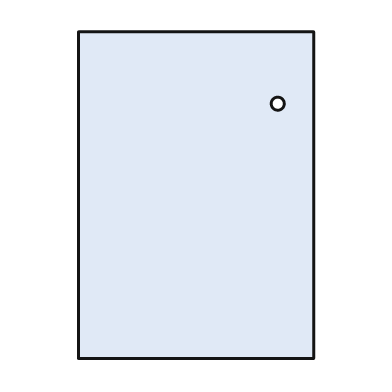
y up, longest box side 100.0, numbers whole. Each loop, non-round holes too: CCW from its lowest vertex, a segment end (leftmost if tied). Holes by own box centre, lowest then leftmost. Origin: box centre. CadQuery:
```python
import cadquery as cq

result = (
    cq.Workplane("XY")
    .moveTo(-36.0, -50.0)
    .lineTo(36.0, -50.0)
    .lineTo(36.0, 50.0)
    .lineTo(-36.0, 50.0)
    .close()
    .moveTo(25.0, 28.0)
    .circle(2.0)
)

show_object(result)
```